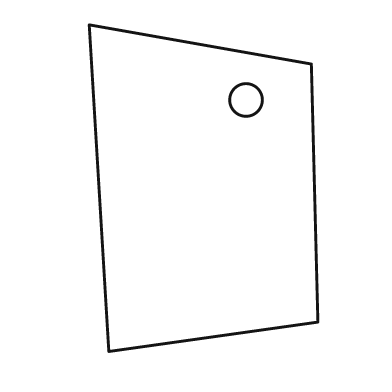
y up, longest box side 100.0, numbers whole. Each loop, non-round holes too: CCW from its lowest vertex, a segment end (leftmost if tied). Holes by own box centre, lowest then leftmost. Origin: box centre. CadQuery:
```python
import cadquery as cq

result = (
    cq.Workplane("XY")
    .moveTo(-29.0, -50.0)
    .lineTo(35.0, -41.0)
    .lineTo(33.0, 38.0)
    .lineTo(-35.0, 50.0)
    .close()
    .moveTo(13.0, 27.0)
    .circle(5.0)
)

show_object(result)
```